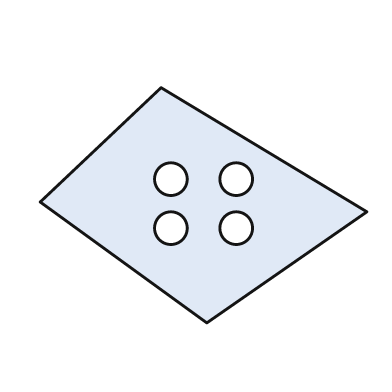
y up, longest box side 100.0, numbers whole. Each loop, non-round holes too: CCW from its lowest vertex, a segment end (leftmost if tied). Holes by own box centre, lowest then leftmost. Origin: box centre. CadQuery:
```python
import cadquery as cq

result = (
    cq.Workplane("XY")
    .moveTo(1.0, -36.0)
    .lineTo(50.0, -2.0)
    .lineTo(-13.0, 36.0)
    .lineTo(-50.0, 1.0)
    .close()
    .moveTo(-10.0, -7.0)
    .circle(5.0)
    .moveTo(10.0, -7.0)
    .circle(5.0)
    .moveTo(-10.0, 8.0)
    .circle(5.0)
    .moveTo(10.0, 8.0)
    .circle(5.0)
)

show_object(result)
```